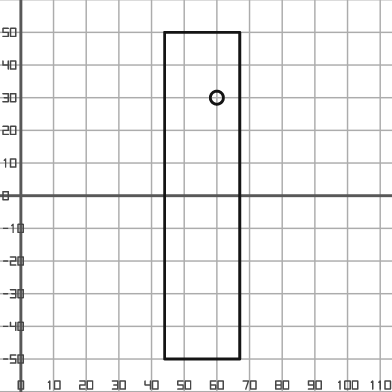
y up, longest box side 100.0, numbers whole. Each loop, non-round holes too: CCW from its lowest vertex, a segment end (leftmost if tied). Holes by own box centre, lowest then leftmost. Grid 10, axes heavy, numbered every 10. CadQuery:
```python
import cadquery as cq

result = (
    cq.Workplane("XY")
    .moveTo(44.0, -50.0)
    .lineTo(67.0, -50.0)
    .lineTo(67.0, 50.0)
    .lineTo(44.0, 50.0)
    .close()
    .moveTo(60.0, 30.0)
    .circle(2.0)
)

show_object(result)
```